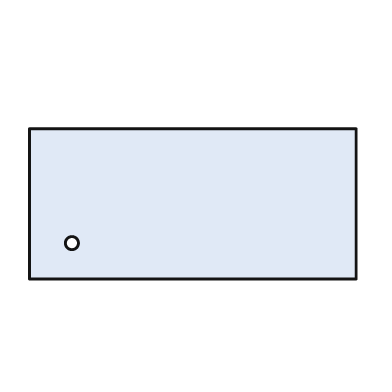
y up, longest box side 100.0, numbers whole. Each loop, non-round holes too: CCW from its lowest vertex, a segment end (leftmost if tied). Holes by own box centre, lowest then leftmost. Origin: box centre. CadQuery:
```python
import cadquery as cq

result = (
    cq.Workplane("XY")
    .moveTo(-50.0, -23.0)
    .lineTo(50.0, -23.0)
    .lineTo(50.0, 23.0)
    .lineTo(-50.0, 23.0)
    .close()
    .moveTo(-37.0, -12.0)
    .circle(2.0)
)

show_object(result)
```